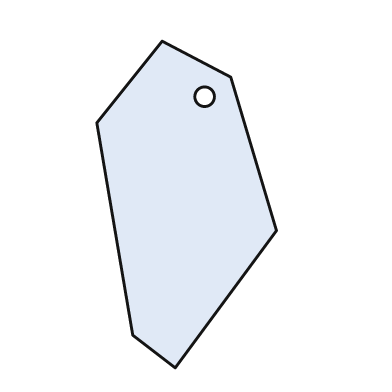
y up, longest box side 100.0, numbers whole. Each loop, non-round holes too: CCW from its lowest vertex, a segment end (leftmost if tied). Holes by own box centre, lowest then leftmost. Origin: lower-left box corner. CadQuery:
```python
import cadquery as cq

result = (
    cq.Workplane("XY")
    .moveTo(24.0, 0.0)
    .lineTo(55.0, 42.0)
    .lineTo(41.0, 89.0)
    .lineTo(20.0, 100.0)
    .lineTo(0.0, 75.0)
    .lineTo(11.0, 10.0)
    .close()
    .moveTo(33.0, 83.0)
    .circle(3.0)
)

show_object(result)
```